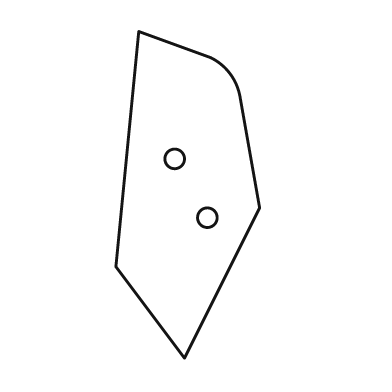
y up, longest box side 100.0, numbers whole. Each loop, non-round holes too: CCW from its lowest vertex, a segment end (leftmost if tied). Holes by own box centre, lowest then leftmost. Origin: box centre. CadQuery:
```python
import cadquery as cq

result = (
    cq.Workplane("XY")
    .moveTo(-1.0, -50.0)
    .lineTo(22.0, -4.0)
    .lineTo(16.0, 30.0)
    .threePointArc((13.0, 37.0), (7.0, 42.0))
    .lineTo(-15.0, 50.0)
    .lineTo(-22.0, -22.0)
    .close()
    .moveTo(6.0, -7.0)
    .circle(3.0)
    .moveTo(-4.0, 11.0)
    .circle(3.0)
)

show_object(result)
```